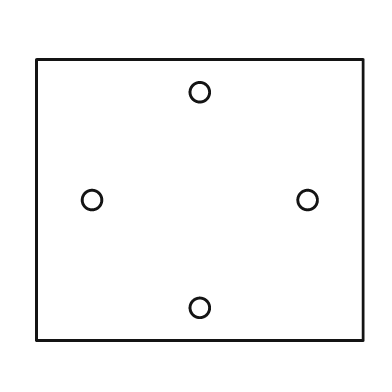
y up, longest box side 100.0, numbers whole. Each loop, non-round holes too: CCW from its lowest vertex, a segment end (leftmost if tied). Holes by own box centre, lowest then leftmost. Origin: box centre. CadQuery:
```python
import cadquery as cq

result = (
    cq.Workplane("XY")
    .moveTo(-50.0, -43.0)
    .lineTo(50.0, -43.0)
    .lineTo(50.0, 43.0)
    .lineTo(-50.0, 43.0)
    .close()
    .moveTo(0.0, -33.0)
    .circle(3.0)
    .moveTo(-33.0, 0.0)
    .circle(3.0)
    .moveTo(33.0, 0.0)
    .circle(3.0)
    .moveTo(0.0, 33.0)
    .circle(3.0)
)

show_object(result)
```